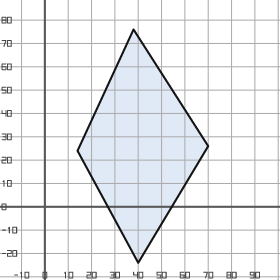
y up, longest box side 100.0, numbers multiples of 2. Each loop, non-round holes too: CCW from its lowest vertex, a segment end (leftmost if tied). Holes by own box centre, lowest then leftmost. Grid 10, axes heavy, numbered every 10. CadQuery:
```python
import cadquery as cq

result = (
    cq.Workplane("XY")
    .moveTo(40.0, -24.0)
    .lineTo(70.0, 26.0)
    .lineTo(38.0, 76.0)
    .lineTo(14.0, 24.0)
    .close()
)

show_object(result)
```